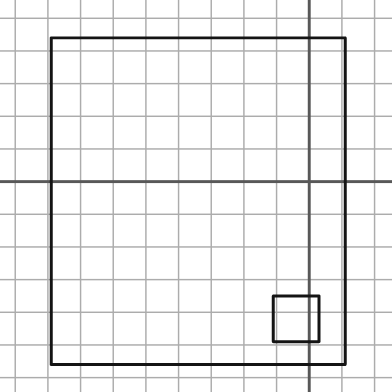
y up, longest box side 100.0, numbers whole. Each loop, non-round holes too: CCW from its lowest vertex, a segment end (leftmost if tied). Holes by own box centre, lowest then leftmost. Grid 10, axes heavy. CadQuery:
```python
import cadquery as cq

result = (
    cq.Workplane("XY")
    .moveTo(-79.0, -56.0)
    .lineTo(11.0, -56.0)
    .lineTo(11.0, 44.0)
    .lineTo(-79.0, 44.0)
    .close()
    .moveTo(-11.0, -49.0)
    .lineTo(3.0, -49.0)
    .lineTo(3.0, -35.0)
    .lineTo(-11.0, -35.0)
    .close()
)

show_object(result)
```